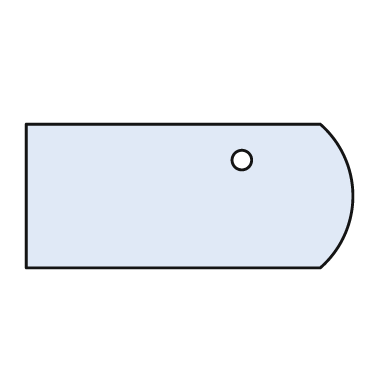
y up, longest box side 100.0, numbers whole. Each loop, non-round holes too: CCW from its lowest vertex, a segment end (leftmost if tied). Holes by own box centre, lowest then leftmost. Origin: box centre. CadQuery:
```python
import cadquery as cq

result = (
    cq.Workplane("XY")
    .moveTo(-50.0, -22.0)
    .lineTo(40.0, -22.0)
    .threePointArc((50.0, 0.0), (40.0, 22.0))
    .lineTo(-50.0, 22.0)
    .close()
    .moveTo(16.0, 11.0)
    .circle(3.0)
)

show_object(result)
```